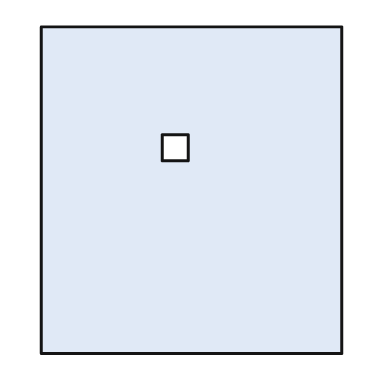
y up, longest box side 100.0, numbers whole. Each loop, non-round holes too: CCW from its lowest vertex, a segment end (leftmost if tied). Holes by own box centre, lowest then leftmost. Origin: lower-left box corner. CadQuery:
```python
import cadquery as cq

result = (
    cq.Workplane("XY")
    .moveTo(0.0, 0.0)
    .lineTo(92.0, 0.0)
    .lineTo(92.0, 100.0)
    .lineTo(0.0, 100.0)
    .close()
    .moveTo(37.0, 59.0)
    .lineTo(45.0, 59.0)
    .lineTo(45.0, 67.0)
    .lineTo(37.0, 67.0)
    .close()
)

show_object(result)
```